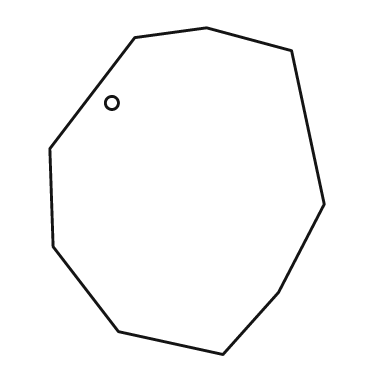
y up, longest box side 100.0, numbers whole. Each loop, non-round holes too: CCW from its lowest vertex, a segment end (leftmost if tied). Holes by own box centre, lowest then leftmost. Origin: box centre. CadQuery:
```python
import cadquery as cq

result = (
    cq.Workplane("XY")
    .moveTo(11.0, -50.0)
    .lineTo(28.0, -31.0)
    .lineTo(42.0, -4.0)
    .lineTo(32.0, 43.0)
    .lineTo(6.0, 50.0)
    .lineTo(-16.0, 47.0)
    .lineTo(-42.0, 13.0)
    .lineTo(-41.0, -17.0)
    .lineTo(-21.0, -43.0)
    .close()
    .moveTo(-23.0, 27.0)
    .circle(2.0)
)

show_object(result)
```